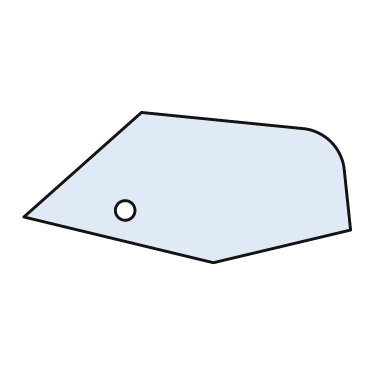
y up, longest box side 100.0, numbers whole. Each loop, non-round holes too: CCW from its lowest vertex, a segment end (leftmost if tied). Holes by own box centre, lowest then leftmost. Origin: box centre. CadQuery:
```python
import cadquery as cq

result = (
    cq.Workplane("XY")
    .moveTo(8.0, -23.0)
    .lineTo(50.0, -13.0)
    .lineTo(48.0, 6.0)
    .threePointArc((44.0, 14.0), (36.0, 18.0))
    .lineTo(-14.0, 23.0)
    .lineTo(-50.0, -9.0)
    .close()
    .moveTo(-19.0, -7.0)
    .circle(3.0)
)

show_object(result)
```